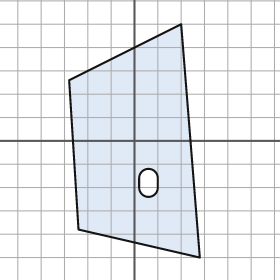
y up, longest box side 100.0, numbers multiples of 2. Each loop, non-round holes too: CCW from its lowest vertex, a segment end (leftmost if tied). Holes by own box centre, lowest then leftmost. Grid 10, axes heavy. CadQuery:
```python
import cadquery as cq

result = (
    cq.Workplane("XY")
    .moveTo(28.0, -50.0)
    .lineTo(20.0, 50.0)
    .lineTo(-28.0, 26.0)
    .lineTo(-24.0, -38.0)
    .close()
    .moveTo(2.0, -20.0)
    .threePointArc((6.0, -24.0), (10.0, -20.0))
    .lineTo(10.0, -16.0)
    .threePointArc((6.0, -12.0), (2.0, -16.0))
    .close()
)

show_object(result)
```